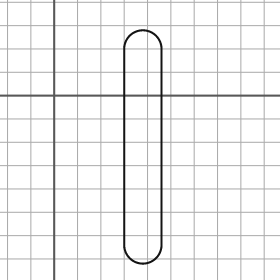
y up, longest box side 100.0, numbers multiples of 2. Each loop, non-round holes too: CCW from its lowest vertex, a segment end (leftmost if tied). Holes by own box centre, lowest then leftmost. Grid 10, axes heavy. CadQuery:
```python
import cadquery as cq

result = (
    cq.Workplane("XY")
    .moveTo(30.0, -64.0)
    .threePointArc((38.0, -72.0), (46.0, -64.0))
    .lineTo(46.0, 20.0)
    .threePointArc((38.0, 28.0), (30.0, 20.0))
    .close()
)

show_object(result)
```